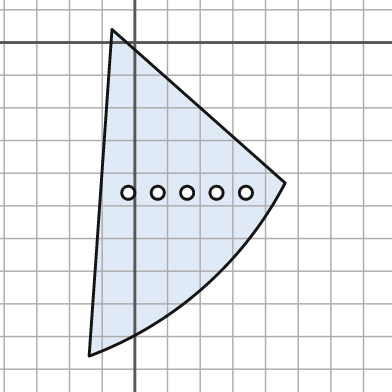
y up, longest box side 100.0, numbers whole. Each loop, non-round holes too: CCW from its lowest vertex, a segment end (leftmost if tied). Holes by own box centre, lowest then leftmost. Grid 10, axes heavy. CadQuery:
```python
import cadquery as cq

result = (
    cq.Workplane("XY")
    .moveTo(-14.0, -96.0)
    .threePointArc((21.0, -75.0), (46.0, -43.0))
    .lineTo(-7.0, 4.0)
    .close()
    .moveTo(-2.0, -46.0)
    .circle(2.0)
    .moveTo(7.0, -46.0)
    .circle(2.0)
    .moveTo(16.0, -46.0)
    .circle(2.0)
    .moveTo(25.0, -46.0)
    .circle(2.0)
    .moveTo(34.0, -46.0)
    .circle(2.0)
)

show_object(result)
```